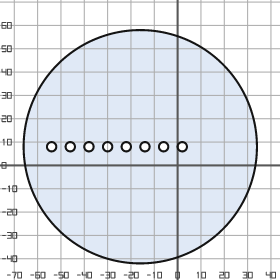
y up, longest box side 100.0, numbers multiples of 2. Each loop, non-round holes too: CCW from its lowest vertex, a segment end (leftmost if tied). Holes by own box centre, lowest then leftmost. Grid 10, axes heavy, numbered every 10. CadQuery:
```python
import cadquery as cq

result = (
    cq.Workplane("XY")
    .moveTo(-16.0, 8.0)
    .circle(50.0)
    .moveTo(-54.0, 8.0)
    .circle(2.0)
    .moveTo(-46.0, 8.0)
    .circle(2.0)
    .moveTo(-38.0, 8.0)
    .circle(2.0)
    .moveTo(-30.0, 8.0)
    .circle(2.0)
    .moveTo(-22.0, 8.0)
    .circle(2.0)
    .moveTo(-14.0, 8.0)
    .circle(2.0)
    .moveTo(-6.0, 8.0)
    .circle(2.0)
    .moveTo(2.0, 8.0)
    .circle(2.0)
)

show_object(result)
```